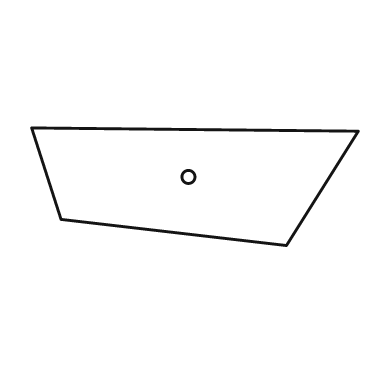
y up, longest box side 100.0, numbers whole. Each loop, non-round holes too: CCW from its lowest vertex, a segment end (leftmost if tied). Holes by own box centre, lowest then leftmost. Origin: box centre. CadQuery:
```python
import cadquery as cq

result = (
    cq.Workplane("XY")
    .moveTo(28.0, -18.0)
    .lineTo(50.0, 17.0)
    .lineTo(-50.0, 18.0)
    .lineTo(-41.0, -10.0)
    .close()
    .moveTo(-2.0, 3.0)
    .circle(2.0)
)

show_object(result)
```